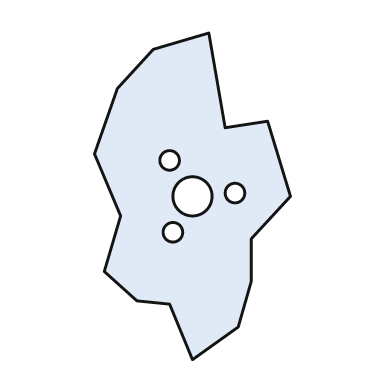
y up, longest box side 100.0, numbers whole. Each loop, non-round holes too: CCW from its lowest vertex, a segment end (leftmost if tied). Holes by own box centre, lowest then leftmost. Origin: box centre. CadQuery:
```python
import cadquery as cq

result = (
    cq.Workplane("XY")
    .moveTo(0.0, -50.0)
    .lineTo(14.0, -40.0)
    .lineTo(18.0, -26.0)
    .lineTo(18.0, -13.0)
    .lineTo(30.0, 0.0)
    .lineTo(23.0, 23.0)
    .lineTo(10.0, 21.0)
    .lineTo(5.0, 50.0)
    .lineTo(-12.0, 45.0)
    .lineTo(-23.0, 33.0)
    .lineTo(-30.0, 13.0)
    .lineTo(-22.0, -6.0)
    .lineTo(-27.0, -23.0)
    .lineTo(-17.0, -32.0)
    .lineTo(-7.0, -33.0)
    .close()
    .moveTo(-6.0, -11.0)
    .circle(3.0)
    .moveTo(0.0, 0.0)
    .circle(6.0)
    .moveTo(13.0, 1.0)
    .circle(3.0)
    .moveTo(-7.0, 11.0)
    .circle(3.0)
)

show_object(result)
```